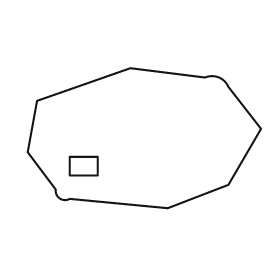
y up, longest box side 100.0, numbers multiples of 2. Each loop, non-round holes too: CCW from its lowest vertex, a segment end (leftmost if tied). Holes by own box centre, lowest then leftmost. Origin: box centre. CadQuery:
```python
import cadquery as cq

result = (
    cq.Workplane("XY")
    .moveTo(10.0, -30.0)
    .lineTo(36.0, -20.0)
    .lineTo(50.0, 4.0)
    .lineTo(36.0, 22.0)
    .threePointArc((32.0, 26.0), (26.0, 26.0))
    .lineTo(-6.0, 30.0)
    .lineTo(-46.0, 16.0)
    .lineTo(-50.0, -6.0)
    .lineTo(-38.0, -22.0)
    .threePointArc((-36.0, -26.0), (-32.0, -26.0))
    .close()
    .moveTo(-32.0, -16.0)
    .lineTo(-20.0, -16.0)
    .lineTo(-20.0, -8.0)
    .lineTo(-32.0, -8.0)
    .close()
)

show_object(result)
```